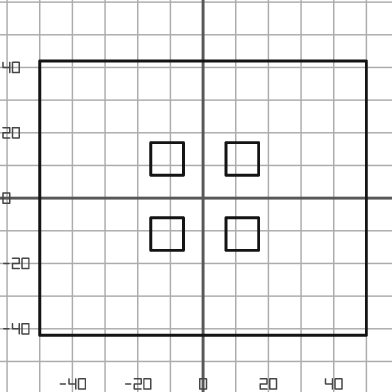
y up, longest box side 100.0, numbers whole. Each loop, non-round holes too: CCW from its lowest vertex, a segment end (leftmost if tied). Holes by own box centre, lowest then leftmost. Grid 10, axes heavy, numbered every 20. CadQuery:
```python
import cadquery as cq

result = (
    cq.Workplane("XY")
    .moveTo(-50.0, -42.0)
    .lineTo(50.0, -42.0)
    .lineTo(50.0, 42.0)
    .lineTo(-50.0, 42.0)
    .close()
    .moveTo(-16.0, -16.0)
    .lineTo(-6.0, -16.0)
    .lineTo(-6.0, -6.0)
    .lineTo(-16.0, -6.0)
    .close()
    .moveTo(7.0, -16.0)
    .lineTo(17.0, -16.0)
    .lineTo(17.0, -6.0)
    .lineTo(7.0, -6.0)
    .close()
    .moveTo(-16.0, 7.0)
    .lineTo(-6.0, 7.0)
    .lineTo(-6.0, 17.0)
    .lineTo(-16.0, 17.0)
    .close()
    .moveTo(7.0, 7.0)
    .lineTo(17.0, 7.0)
    .lineTo(17.0, 17.0)
    .lineTo(7.0, 17.0)
    .close()
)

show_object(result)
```